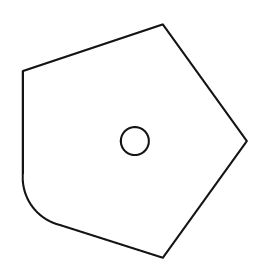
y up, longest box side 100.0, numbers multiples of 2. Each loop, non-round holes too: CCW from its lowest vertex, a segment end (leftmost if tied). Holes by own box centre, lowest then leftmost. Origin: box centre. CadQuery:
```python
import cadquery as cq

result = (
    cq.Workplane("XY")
    .moveTo(12.0, -50.0)
    .lineTo(48.0, 0.0)
    .lineTo(12.0, 50.0)
    .lineTo(-48.0, 30.0)
    .lineTo(-48.0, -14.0)
    .threePointArc((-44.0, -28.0), (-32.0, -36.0))
    .close()
    .moveTo(0.0, 0.0)
    .circle(6.0)
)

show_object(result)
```